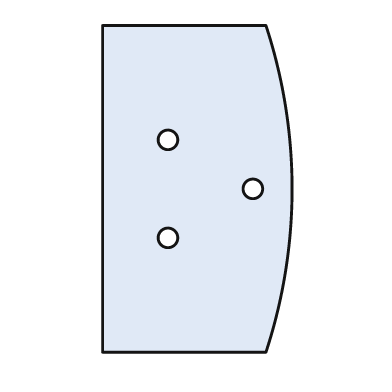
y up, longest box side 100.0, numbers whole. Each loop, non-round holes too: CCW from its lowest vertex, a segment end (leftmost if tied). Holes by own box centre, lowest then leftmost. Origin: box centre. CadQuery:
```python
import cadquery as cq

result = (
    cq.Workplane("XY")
    .moveTo(-29.0, -50.0)
    .lineTo(21.0, -50.0)
    .threePointArc((29.0, 0.0), (21.0, 50.0))
    .lineTo(-29.0, 50.0)
    .close()
    .moveTo(-9.0, -15.0)
    .circle(3.0)
    .moveTo(17.0, 0.0)
    .circle(3.0)
    .moveTo(-9.0, 15.0)
    .circle(3.0)
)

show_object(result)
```